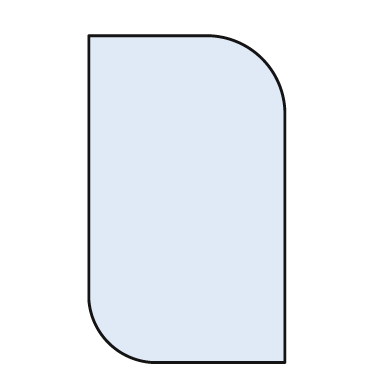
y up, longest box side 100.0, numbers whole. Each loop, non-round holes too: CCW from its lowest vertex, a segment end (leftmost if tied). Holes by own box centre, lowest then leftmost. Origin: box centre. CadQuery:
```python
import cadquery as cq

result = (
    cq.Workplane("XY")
    .moveTo(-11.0, -50.0)
    .lineTo(30.0, -50.0)
    .lineTo(30.0, 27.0)
    .threePointArc((23.0, 43.0), (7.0, 50.0))
    .lineTo(-30.0, 50.0)
    .lineTo(-30.0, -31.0)
    .threePointArc((-24.0, -44.0), (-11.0, -50.0))
    .close()
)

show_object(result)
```